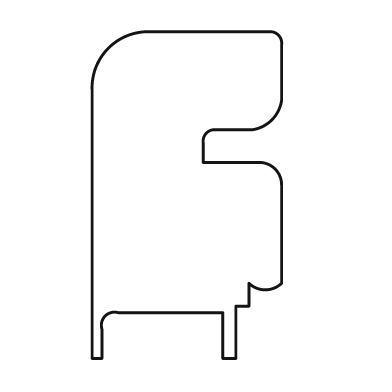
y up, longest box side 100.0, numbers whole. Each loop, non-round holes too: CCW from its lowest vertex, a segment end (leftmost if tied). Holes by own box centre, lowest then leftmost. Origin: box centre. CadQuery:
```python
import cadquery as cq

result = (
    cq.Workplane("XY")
    .moveTo(-29.0, -50.0)
    .lineTo(-26.0, -50.0)
    .lineTo(-26.0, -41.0)
    .threePointArc((-25.0, -37.0), (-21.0, -36.0))
    .lineTo(11.0, -36.0)
    .lineTo(11.0, -50.0)
    .lineTo(15.0, -50.0)
    .lineTo(15.0, -34.0)
    .lineTo(19.0, -34.0)
    .lineTo(19.0, -27.0)
    .threePointArc((24.0, -29.0), (29.0, -27.0))
    .lineTo(29.0, 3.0)
    .threePointArc((27.0, 8.0), (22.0, 10.0))
    .lineTo(5.0, 10.0)
    .lineTo(5.0, 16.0)
    .threePointArc((6.0, 19.0), (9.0, 20.0))
    .lineTo(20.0, 20.0)
    .threePointArc((26.0, 23.0), (29.0, 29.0))
    .lineTo(29.0, 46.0)
    .threePointArc((28.0, 49.0), (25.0, 50.0))
    .lineTo(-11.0, 50.0)
    .threePointArc((-24.0, 45.0), (-29.0, 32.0))
    .close()
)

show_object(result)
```